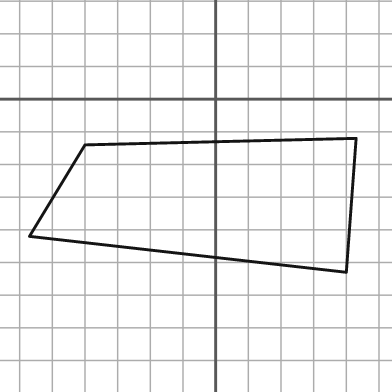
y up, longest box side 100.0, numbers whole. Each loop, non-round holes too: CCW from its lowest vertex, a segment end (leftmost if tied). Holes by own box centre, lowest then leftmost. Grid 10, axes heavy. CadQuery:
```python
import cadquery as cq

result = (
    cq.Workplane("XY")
    .moveTo(40.0, -53.0)
    .lineTo(43.0, -12.0)
    .lineTo(-40.0, -14.0)
    .lineTo(-57.0, -42.0)
    .close()
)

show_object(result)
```